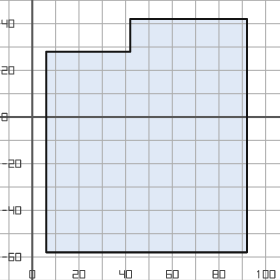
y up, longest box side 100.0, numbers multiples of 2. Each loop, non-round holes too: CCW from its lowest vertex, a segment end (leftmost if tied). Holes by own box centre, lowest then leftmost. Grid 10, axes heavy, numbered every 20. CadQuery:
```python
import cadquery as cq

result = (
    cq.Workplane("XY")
    .moveTo(6.0, -58.0)
    .lineTo(92.0, -58.0)
    .lineTo(92.0, 42.0)
    .lineTo(42.0, 42.0)
    .lineTo(42.0, 28.0)
    .lineTo(6.0, 28.0)
    .close()
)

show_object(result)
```